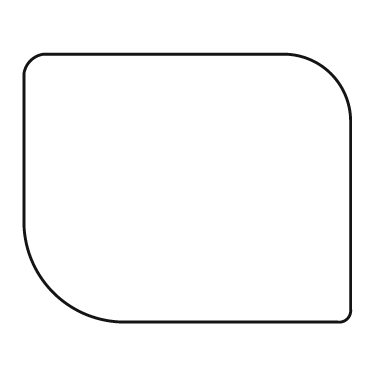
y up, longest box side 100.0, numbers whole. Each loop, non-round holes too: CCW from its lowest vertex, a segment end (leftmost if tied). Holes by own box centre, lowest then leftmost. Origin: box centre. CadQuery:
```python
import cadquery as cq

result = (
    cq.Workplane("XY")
    .moveTo(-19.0, -41.0)
    .lineTo(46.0, -41.0)
    .threePointArc((49.0, -40.0), (50.0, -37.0))
    .lineTo(50.0, 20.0)
    .threePointArc((44.0, 35.0), (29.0, 41.0))
    .lineTo(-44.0, 41.0)
    .threePointArc((-48.0, 39.0), (-50.0, 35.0))
    .lineTo(-50.0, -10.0)
    .threePointArc((-41.0, -32.0), (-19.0, -41.0))
    .close()
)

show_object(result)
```